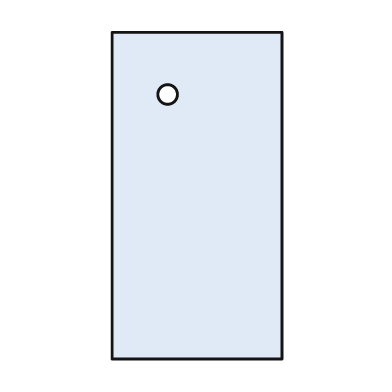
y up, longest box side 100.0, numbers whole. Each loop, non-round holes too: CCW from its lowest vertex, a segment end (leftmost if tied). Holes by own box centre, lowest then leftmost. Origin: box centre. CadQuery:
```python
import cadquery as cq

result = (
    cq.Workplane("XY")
    .moveTo(-26.0, -50.0)
    .lineTo(26.0, -50.0)
    .lineTo(26.0, 50.0)
    .lineTo(-26.0, 50.0)
    .close()
    .moveTo(-9.0, 31.0)
    .circle(3.0)
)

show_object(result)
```